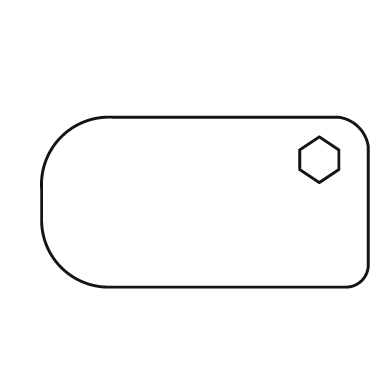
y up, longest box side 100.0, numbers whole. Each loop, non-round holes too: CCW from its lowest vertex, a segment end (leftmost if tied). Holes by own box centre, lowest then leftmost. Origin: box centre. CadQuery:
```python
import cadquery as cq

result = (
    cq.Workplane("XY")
    .moveTo(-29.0, -26.0)
    .lineTo(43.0, -26.0)
    .threePointArc((48.0, -24.0), (50.0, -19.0))
    .lineTo(50.0, 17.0)
    .threePointArc((47.0, 23.0), (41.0, 26.0))
    .lineTo(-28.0, 26.0)
    .threePointArc((-44.0, 20.0), (-50.0, 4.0))
    .lineTo(-50.0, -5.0)
    .threePointArc((-44.0, -20.0), (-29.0, -26.0))
    .close()
    .moveTo(35.0, 6.0)
    .lineTo(41.0, 10.0)
    .lineTo(41.0, 16.0)
    .lineTo(35.0, 20.0)
    .lineTo(29.0, 16.0)
    .lineTo(29.0, 10.0)
    .close()
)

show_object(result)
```